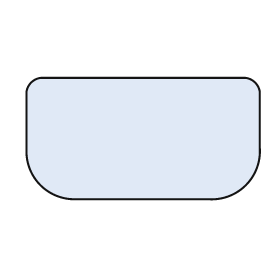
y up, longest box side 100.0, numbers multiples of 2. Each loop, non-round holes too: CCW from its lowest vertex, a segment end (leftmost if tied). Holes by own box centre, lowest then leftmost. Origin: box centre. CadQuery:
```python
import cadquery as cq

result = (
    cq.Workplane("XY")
    .moveTo(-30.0, -26.0)
    .lineTo(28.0, -26.0)
    .threePointArc((44.0, -20.0), (50.0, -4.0))
    .lineTo(50.0, 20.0)
    .threePointArc((48.0, 24.0), (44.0, 26.0))
    .lineTo(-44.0, 26.0)
    .threePointArc((-48.0, 24.0), (-50.0, 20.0))
    .lineTo(-50.0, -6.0)
    .threePointArc((-44.0, -20.0), (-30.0, -26.0))
    .close()
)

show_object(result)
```